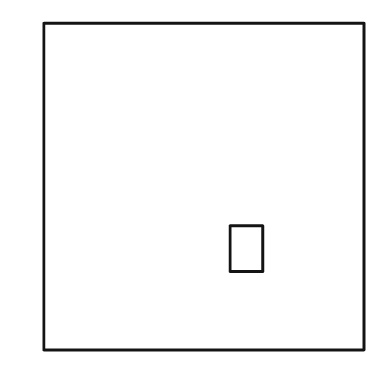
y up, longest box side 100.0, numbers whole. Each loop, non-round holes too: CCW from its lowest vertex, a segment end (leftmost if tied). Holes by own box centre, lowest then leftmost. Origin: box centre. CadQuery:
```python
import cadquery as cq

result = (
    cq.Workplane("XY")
    .moveTo(-49.0, -50.0)
    .lineTo(49.0, -50.0)
    .lineTo(49.0, 50.0)
    .lineTo(-49.0, 50.0)
    .close()
    .moveTo(8.0, -26.0)
    .lineTo(18.0, -26.0)
    .lineTo(18.0, -12.0)
    .lineTo(8.0, -12.0)
    .close()
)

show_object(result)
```